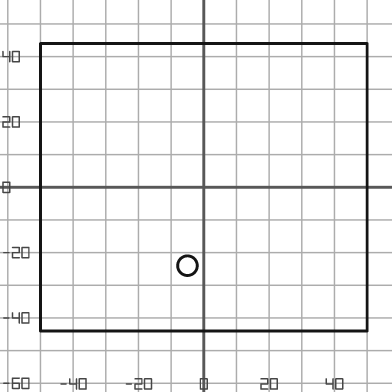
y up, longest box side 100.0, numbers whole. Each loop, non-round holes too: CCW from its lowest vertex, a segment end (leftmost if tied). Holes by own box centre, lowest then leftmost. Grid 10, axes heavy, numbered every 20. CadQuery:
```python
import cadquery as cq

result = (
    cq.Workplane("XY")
    .moveTo(-50.0, -44.0)
    .lineTo(50.0, -44.0)
    .lineTo(50.0, 44.0)
    .lineTo(-50.0, 44.0)
    .close()
    .moveTo(-5.0, -24.0)
    .circle(3.0)
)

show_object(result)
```